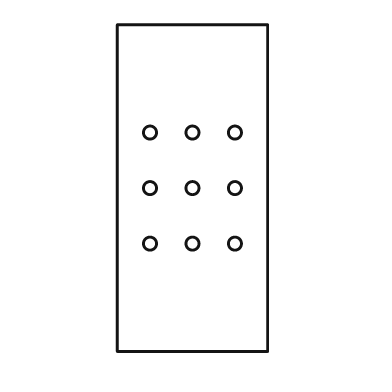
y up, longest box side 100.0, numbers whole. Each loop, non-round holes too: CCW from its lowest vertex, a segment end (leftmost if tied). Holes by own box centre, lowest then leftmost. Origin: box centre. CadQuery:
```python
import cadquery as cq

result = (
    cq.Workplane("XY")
    .moveTo(-23.0, -50.0)
    .lineTo(23.0, -50.0)
    .lineTo(23.0, 50.0)
    .lineTo(-23.0, 50.0)
    .close()
    .moveTo(-13.0, -17.0)
    .circle(2.0)
    .moveTo(0.0, -17.0)
    .circle(2.0)
    .moveTo(13.0, -17.0)
    .circle(2.0)
    .moveTo(-13.0, 0.0)
    .circle(2.0)
    .moveTo(0.0, 0.0)
    .circle(2.0)
    .moveTo(13.0, 0.0)
    .circle(2.0)
    .moveTo(-13.0, 17.0)
    .circle(2.0)
    .moveTo(0.0, 17.0)
    .circle(2.0)
    .moveTo(13.0, 17.0)
    .circle(2.0)
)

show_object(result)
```